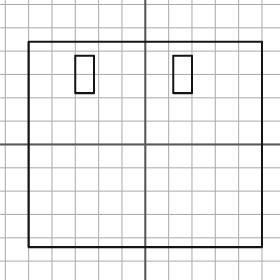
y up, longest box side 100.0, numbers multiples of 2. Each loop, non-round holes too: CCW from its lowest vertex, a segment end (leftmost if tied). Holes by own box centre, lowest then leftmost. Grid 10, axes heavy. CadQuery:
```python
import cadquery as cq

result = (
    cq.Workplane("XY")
    .moveTo(-50.0, -44.0)
    .lineTo(50.0, -44.0)
    .lineTo(50.0, 44.0)
    .lineTo(-50.0, 44.0)
    .close()
    .moveTo(-30.0, 22.0)
    .lineTo(-22.0, 22.0)
    .lineTo(-22.0, 38.0)
    .lineTo(-30.0, 38.0)
    .close()
    .moveTo(12.0, 22.0)
    .lineTo(20.0, 22.0)
    .lineTo(20.0, 38.0)
    .lineTo(12.0, 38.0)
    .close()
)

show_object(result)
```